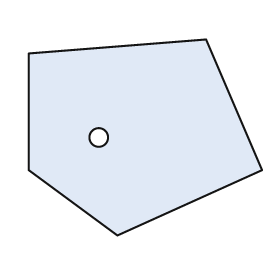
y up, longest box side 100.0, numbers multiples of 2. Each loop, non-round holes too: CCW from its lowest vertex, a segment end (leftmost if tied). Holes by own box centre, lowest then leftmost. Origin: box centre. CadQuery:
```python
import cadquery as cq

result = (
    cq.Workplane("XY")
    .moveTo(-12.0, -42.0)
    .lineTo(50.0, -14.0)
    .lineTo(26.0, 42.0)
    .lineTo(-50.0, 36.0)
    .lineTo(-50.0, -14.0)
    .close()
    .moveTo(-20.0, 0.0)
    .circle(4.0)
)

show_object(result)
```